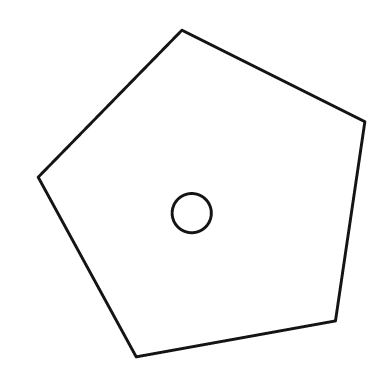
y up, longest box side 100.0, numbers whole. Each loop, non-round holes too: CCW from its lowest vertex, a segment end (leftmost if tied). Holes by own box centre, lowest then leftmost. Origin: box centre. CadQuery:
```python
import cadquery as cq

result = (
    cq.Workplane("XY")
    .moveTo(-20.0, -50.0)
    .lineTo(41.0, -39.0)
    .lineTo(50.0, 22.0)
    .lineTo(-6.0, 50.0)
    .lineTo(-50.0, 5.0)
    .close()
    .moveTo(-3.0, -6.0)
    .circle(6.0)
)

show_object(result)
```